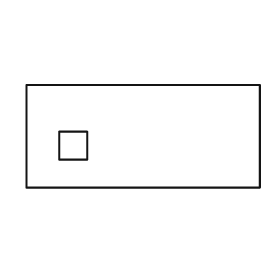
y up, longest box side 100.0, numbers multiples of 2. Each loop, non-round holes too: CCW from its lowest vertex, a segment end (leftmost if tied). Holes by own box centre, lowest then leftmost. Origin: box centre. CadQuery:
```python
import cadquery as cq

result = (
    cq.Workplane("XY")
    .moveTo(-50.0, -22.0)
    .lineTo(50.0, -22.0)
    .lineTo(50.0, 22.0)
    .lineTo(-50.0, 22.0)
    .close()
    .moveTo(-36.0, -10.0)
    .lineTo(-24.0, -10.0)
    .lineTo(-24.0, 2.0)
    .lineTo(-36.0, 2.0)
    .close()
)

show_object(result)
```